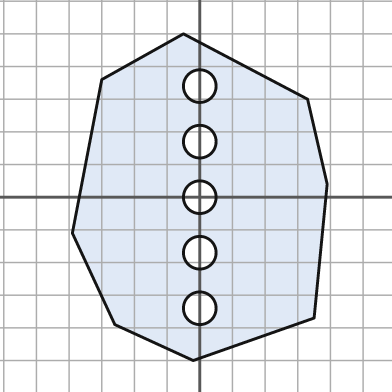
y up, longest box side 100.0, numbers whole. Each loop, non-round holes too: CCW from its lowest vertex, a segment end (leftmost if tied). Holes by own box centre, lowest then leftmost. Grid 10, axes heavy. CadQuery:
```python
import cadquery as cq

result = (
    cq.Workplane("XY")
    .moveTo(-2.0, -50.0)
    .lineTo(35.0, -37.0)
    .lineTo(39.0, 4.0)
    .lineTo(33.0, 30.0)
    .lineTo(-5.0, 50.0)
    .lineTo(-30.0, 36.0)
    .lineTo(-39.0, -11.0)
    .lineTo(-26.0, -39.0)
    .close()
    .moveTo(0.0, -34.0)
    .circle(5.0)
    .moveTo(0.0, -17.0)
    .circle(5.0)
    .moveTo(0.0, 0.0)
    .circle(5.0)
    .moveTo(0.0, 17.0)
    .circle(5.0)
    .moveTo(0.0, 34.0)
    .circle(5.0)
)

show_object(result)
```